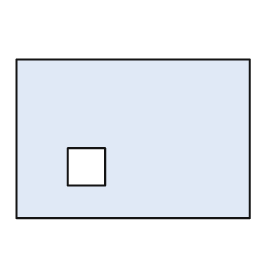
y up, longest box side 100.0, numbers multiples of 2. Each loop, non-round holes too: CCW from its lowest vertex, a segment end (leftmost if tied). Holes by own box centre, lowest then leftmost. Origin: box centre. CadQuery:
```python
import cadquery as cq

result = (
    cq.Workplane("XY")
    .moveTo(-50.0, -34.0)
    .lineTo(50.0, -34.0)
    .lineTo(50.0, 34.0)
    .lineTo(-50.0, 34.0)
    .close()
    .moveTo(-28.0, -20.0)
    .lineTo(-12.0, -20.0)
    .lineTo(-12.0, -4.0)
    .lineTo(-28.0, -4.0)
    .close()
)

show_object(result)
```